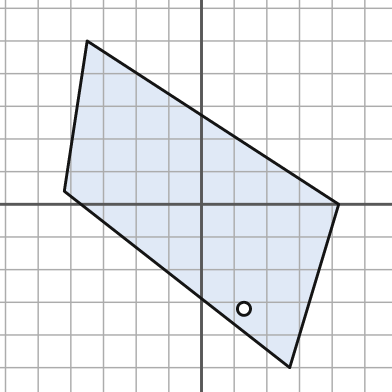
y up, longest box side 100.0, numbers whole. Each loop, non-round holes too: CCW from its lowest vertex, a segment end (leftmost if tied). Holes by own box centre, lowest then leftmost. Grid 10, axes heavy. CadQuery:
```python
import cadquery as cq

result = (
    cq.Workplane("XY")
    .moveTo(27.0, -50.0)
    .lineTo(42.0, 0.0)
    .lineTo(-35.0, 50.0)
    .lineTo(-42.0, 4.0)
    .close()
    .moveTo(13.0, -32.0)
    .circle(2.0)
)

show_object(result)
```